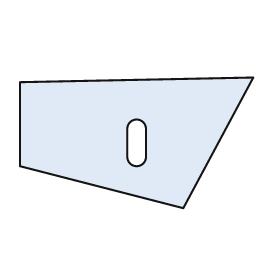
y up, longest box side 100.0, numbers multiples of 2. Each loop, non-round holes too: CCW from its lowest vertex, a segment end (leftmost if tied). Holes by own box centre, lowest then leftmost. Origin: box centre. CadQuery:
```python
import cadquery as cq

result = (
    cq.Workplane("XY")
    .moveTo(20.0, -28.0)
    .lineTo(50.0, 28.0)
    .lineTo(-50.0, 26.0)
    .lineTo(-50.0, -10.0)
    .close()
    .moveTo(-4.0, -6.0)
    .threePointArc((0.0, -10.0), (4.0, -6.0))
    .lineTo(4.0, 6.0)
    .threePointArc((0.0, 10.0), (-4.0, 6.0))
    .close()
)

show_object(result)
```